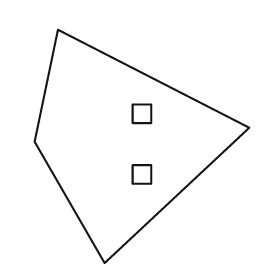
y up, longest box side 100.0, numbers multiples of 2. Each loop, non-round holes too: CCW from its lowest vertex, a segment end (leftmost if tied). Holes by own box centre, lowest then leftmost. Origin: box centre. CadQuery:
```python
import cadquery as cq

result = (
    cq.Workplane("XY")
    .moveTo(-16.0, -50.0)
    .lineTo(46.0, 8.0)
    .lineTo(-36.0, 50.0)
    .lineTo(-46.0, 2.0)
    .close()
    .moveTo(-4.0, -16.0)
    .lineTo(4.0, -16.0)
    .lineTo(4.0, -8.0)
    .lineTo(-4.0, -8.0)
    .close()
    .moveTo(-4.0, 10.0)
    .lineTo(4.0, 10.0)
    .lineTo(4.0, 18.0)
    .lineTo(-4.0, 18.0)
    .close()
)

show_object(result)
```